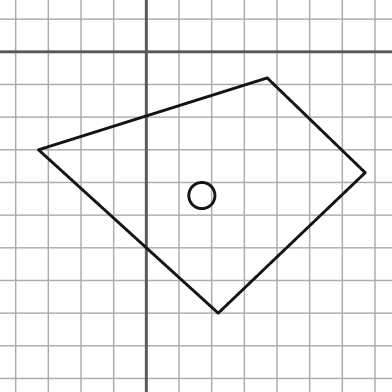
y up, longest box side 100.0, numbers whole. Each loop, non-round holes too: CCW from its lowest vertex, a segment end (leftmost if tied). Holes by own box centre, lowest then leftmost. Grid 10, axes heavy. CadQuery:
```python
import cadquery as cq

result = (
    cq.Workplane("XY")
    .moveTo(22.0, -80.0)
    .lineTo(67.0, -37.0)
    .lineTo(37.0, -8.0)
    .lineTo(-33.0, -30.0)
    .close()
    .moveTo(17.0, -44.0)
    .circle(4.0)
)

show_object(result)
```